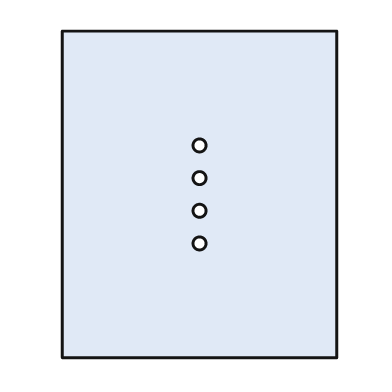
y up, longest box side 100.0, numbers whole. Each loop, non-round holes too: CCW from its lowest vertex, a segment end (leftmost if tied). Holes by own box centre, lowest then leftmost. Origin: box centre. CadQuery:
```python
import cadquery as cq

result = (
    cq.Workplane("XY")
    .moveTo(-42.0, -50.0)
    .lineTo(42.0, -50.0)
    .lineTo(42.0, 50.0)
    .lineTo(-42.0, 50.0)
    .close()
    .moveTo(0.0, -15.0)
    .circle(2.0)
    .moveTo(0.0, -5.0)
    .circle(2.0)
    .moveTo(0.0, 5.0)
    .circle(2.0)
    .moveTo(0.0, 15.0)
    .circle(2.0)
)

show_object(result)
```